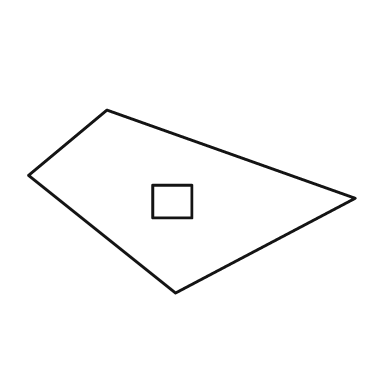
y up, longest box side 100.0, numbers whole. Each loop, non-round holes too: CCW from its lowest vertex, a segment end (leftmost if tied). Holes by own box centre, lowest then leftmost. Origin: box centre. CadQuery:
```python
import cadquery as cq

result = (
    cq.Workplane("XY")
    .moveTo(-5.0, -28.0)
    .lineTo(50.0, 1.0)
    .lineTo(-26.0, 28.0)
    .lineTo(-50.0, 8.0)
    .close()
    .moveTo(-12.0, -5.0)
    .lineTo(0.0, -5.0)
    .lineTo(0.0, 5.0)
    .lineTo(-12.0, 5.0)
    .close()
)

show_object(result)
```